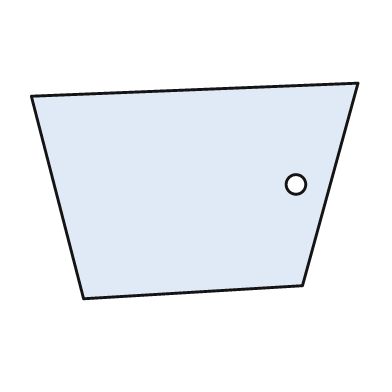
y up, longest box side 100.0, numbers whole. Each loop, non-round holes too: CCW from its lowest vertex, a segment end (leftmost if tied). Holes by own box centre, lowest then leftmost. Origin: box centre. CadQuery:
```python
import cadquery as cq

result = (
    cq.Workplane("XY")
    .moveTo(-34.0, -33.0)
    .lineTo(33.0, -29.0)
    .lineTo(50.0, 33.0)
    .lineTo(-50.0, 29.0)
    .close()
    .moveTo(31.0, 2.0)
    .circle(3.0)
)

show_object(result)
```